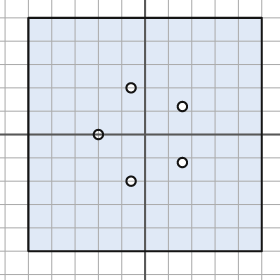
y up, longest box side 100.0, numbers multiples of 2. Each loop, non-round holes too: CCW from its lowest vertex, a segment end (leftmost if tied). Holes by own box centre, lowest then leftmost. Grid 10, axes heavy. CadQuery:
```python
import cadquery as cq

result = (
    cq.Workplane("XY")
    .moveTo(-50.0, -50.0)
    .lineTo(50.0, -50.0)
    .lineTo(50.0, 50.0)
    .lineTo(-50.0, 50.0)
    .close()
    .moveTo(-6.0, -20.0)
    .circle(2.0)
    .moveTo(16.0, -12.0)
    .circle(2.0)
    .moveTo(-20.0, 0.0)
    .circle(2.0)
    .moveTo(16.0, 12.0)
    .circle(2.0)
    .moveTo(-6.0, 20.0)
    .circle(2.0)
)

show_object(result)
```